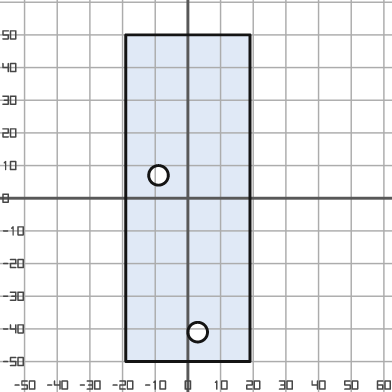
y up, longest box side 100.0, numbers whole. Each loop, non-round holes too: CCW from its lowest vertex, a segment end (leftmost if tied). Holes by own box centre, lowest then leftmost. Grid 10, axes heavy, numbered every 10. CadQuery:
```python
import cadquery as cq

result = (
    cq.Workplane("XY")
    .moveTo(-19.0, -50.0)
    .lineTo(19.0, -50.0)
    .lineTo(19.0, 50.0)
    .lineTo(-19.0, 50.0)
    .close()
    .moveTo(3.0, -41.0)
    .circle(3.0)
    .moveTo(-9.0, 7.0)
    .circle(3.0)
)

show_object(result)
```